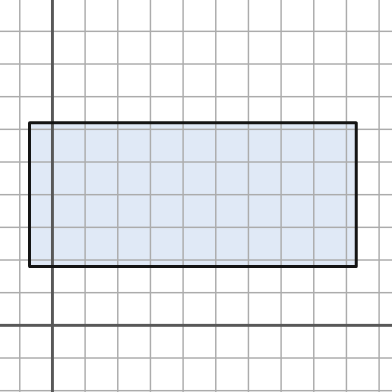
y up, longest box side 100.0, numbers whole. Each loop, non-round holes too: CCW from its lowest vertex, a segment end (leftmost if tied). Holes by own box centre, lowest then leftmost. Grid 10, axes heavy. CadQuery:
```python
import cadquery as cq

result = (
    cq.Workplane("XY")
    .moveTo(-7.0, 18.0)
    .lineTo(93.0, 18.0)
    .lineTo(93.0, 62.0)
    .lineTo(-7.0, 62.0)
    .close()
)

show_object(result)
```